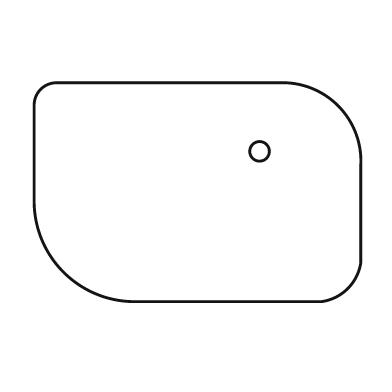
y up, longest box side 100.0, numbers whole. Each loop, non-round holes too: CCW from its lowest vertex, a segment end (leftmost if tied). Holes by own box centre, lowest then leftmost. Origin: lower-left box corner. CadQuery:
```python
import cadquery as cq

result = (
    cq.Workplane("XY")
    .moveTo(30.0, 0.0)
    .lineTo(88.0, 0.0)
    .threePointArc((96.0, 4.0), (100.0, 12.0))
    .lineTo(100.0, 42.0)
    .threePointArc((93.0, 60.0), (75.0, 67.0))
    .lineTo(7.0, 67.0)
    .threePointArc((2.0, 65.0), (0.0, 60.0))
    .lineTo(0.0, 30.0)
    .threePointArc((9.0, 9.0), (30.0, 0.0))
    .close()
    .moveTo(69.0, 46.0)
    .circle(3.0)
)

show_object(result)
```